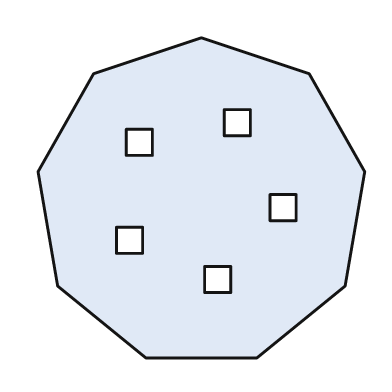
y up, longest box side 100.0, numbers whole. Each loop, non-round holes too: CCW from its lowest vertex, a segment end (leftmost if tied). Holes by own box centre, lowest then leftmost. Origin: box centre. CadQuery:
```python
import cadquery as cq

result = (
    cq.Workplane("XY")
    .moveTo(-17.0, -49.0)
    .lineTo(17.0, -49.0)
    .lineTo(44.0, -27.0)
    .lineTo(50.0, 8.0)
    .lineTo(33.0, 38.0)
    .lineTo(0.0, 49.0)
    .lineTo(-33.0, 38.0)
    .lineTo(-50.0, 8.0)
    .lineTo(-44.0, -27.0)
    .close()
    .moveTo(1.0, -29.0)
    .lineTo(9.0, -29.0)
    .lineTo(9.0, -21.0)
    .lineTo(1.0, -21.0)
    .close()
    .moveTo(-26.0, -17.0)
    .lineTo(-18.0, -17.0)
    .lineTo(-18.0, -9.0)
    .lineTo(-26.0, -9.0)
    .close()
    .moveTo(21.0, -7.0)
    .lineTo(29.0, -7.0)
    .lineTo(29.0, 1.0)
    .lineTo(21.0, 1.0)
    .close()
    .moveTo(-23.0, 13.0)
    .lineTo(-15.0, 13.0)
    .lineTo(-15.0, 21.0)
    .lineTo(-23.0, 21.0)
    .close()
    .moveTo(7.0, 19.0)
    .lineTo(15.0, 19.0)
    .lineTo(15.0, 27.0)
    .lineTo(7.0, 27.0)
    .close()
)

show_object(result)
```